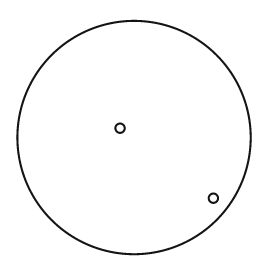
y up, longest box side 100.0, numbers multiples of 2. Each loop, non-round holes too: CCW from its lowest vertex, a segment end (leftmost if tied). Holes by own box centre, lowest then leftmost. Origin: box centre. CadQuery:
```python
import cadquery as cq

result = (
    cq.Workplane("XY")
    .moveTo(0.0, 0.0)
    .circle(50.0)
    .moveTo(34.0, -26.0)
    .circle(2.0)
    .moveTo(-6.0, 4.0)
    .circle(2.0)
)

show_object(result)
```